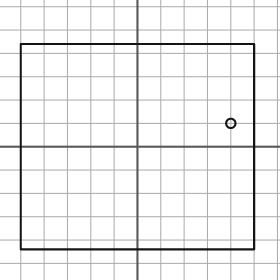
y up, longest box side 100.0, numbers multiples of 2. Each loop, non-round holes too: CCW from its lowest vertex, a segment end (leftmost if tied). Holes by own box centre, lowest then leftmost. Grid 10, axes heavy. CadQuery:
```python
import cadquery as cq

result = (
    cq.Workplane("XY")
    .moveTo(-50.0, -44.0)
    .lineTo(50.0, -44.0)
    .lineTo(50.0, 44.0)
    .lineTo(-50.0, 44.0)
    .close()
    .moveTo(40.0, 10.0)
    .circle(2.0)
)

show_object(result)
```